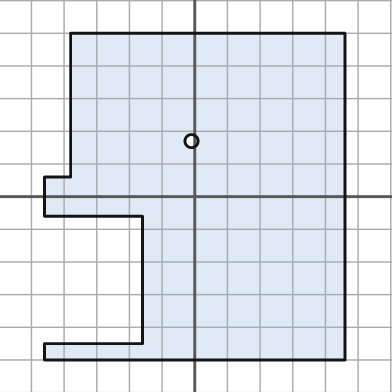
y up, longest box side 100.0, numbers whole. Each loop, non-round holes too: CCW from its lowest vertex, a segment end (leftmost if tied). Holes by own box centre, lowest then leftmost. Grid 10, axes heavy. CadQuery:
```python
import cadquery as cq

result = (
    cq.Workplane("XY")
    .moveTo(-46.0, -50.0)
    .lineTo(46.0, -50.0)
    .lineTo(46.0, 50.0)
    .lineTo(-38.0, 50.0)
    .lineTo(-38.0, 6.0)
    .lineTo(-46.0, 6.0)
    .lineTo(-46.0, -6.0)
    .lineTo(-16.0, -6.0)
    .lineTo(-16.0, -45.0)
    .lineTo(-46.0, -45.0)
    .close()
    .moveTo(-1.0, 17.0)
    .circle(2.0)
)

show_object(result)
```